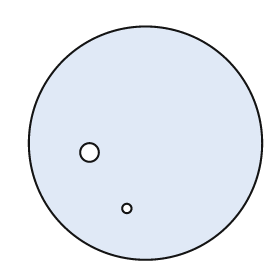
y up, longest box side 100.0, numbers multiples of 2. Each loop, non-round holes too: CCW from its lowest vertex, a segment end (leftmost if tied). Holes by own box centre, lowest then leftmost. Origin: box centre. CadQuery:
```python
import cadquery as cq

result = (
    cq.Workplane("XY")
    .moveTo(0.0, 0.0)
    .circle(50.0)
    .moveTo(-8.0, -28.0)
    .circle(2.0)
    .moveTo(-24.0, -4.0)
    .circle(4.0)
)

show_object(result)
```